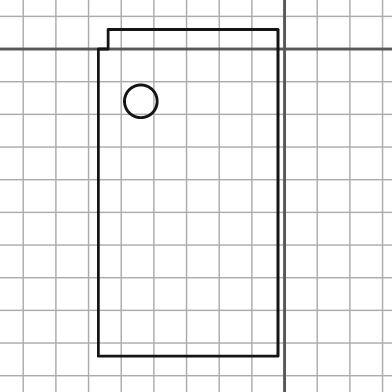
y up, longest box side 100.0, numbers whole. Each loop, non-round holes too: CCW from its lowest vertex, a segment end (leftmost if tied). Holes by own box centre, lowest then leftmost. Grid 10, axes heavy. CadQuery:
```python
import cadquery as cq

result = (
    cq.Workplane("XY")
    .moveTo(-57.0, -94.0)
    .lineTo(-2.0, -94.0)
    .lineTo(-2.0, 6.0)
    .lineTo(-54.0, 6.0)
    .lineTo(-54.0, 0.0)
    .lineTo(-57.0, 0.0)
    .close()
    .moveTo(-44.0, -16.0)
    .circle(5.0)
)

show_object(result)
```